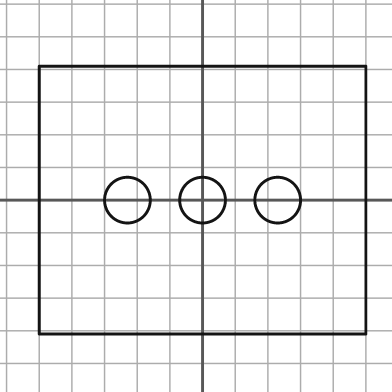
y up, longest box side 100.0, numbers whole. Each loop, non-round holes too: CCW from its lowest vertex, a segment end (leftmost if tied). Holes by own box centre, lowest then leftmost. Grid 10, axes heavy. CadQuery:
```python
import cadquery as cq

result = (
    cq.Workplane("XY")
    .moveTo(-50.0, -41.0)
    .lineTo(50.0, -41.0)
    .lineTo(50.0, 41.0)
    .lineTo(-50.0, 41.0)
    .close()
    .moveTo(-23.0, 0.0)
    .circle(7.0)
    .moveTo(0.0, 0.0)
    .circle(7.0)
    .moveTo(23.0, 0.0)
    .circle(7.0)
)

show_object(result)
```